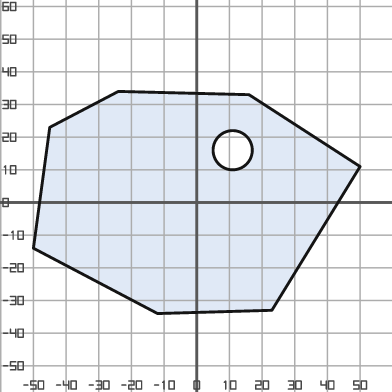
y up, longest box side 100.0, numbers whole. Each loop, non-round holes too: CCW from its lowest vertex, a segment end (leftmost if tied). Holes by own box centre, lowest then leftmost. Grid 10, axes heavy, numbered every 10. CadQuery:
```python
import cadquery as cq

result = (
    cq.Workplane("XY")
    .moveTo(-12.0, -34.0)
    .lineTo(23.0, -33.0)
    .lineTo(50.0, 11.0)
    .lineTo(16.0, 33.0)
    .lineTo(-24.0, 34.0)
    .lineTo(-45.0, 23.0)
    .lineTo(-50.0, -14.0)
    .close()
    .moveTo(11.0, 16.0)
    .circle(6.0)
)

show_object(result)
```